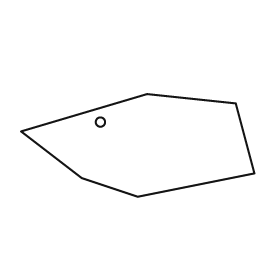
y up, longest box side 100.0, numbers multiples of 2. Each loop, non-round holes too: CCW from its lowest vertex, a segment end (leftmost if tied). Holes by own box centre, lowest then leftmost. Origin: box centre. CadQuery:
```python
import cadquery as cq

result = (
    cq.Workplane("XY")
    .moveTo(0.0, -22.0)
    .lineTo(50.0, -12.0)
    .lineTo(42.0, 18.0)
    .lineTo(4.0, 22.0)
    .lineTo(-50.0, 6.0)
    .lineTo(-24.0, -14.0)
    .close()
    .moveTo(-16.0, 10.0)
    .circle(2.0)
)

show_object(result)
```